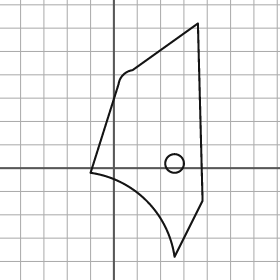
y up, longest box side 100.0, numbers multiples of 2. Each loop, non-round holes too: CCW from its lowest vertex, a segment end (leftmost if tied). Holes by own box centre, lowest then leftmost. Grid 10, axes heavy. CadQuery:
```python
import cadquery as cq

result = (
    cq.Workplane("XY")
    .moveTo(26.0, -38.0)
    .lineTo(38.0, -14.0)
    .lineTo(36.0, 62.0)
    .lineTo(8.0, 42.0)
    .threePointArc((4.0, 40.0), (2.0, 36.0))
    .lineTo(-10.0, -2.0)
    .threePointArc((14.0, -14.0), (26.0, -38.0))
    .close()
    .moveTo(26.0, 2.0)
    .circle(4.0)
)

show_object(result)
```